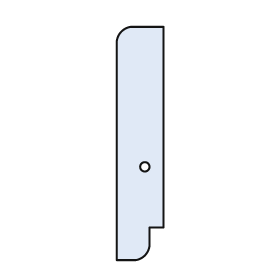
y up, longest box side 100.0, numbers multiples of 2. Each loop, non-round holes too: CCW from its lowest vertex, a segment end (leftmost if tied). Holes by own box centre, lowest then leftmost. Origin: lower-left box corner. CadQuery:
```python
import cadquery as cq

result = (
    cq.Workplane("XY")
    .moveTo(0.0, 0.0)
    .lineTo(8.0, 0.0)
    .threePointArc((12.0, 2.0), (14.0, 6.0))
    .lineTo(14.0, 14.0)
    .lineTo(20.0, 14.0)
    .lineTo(20.0, 100.0)
    .lineTo(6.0, 100.0)
    .threePointArc((2.0, 98.0), (0.0, 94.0))
    .close()
    .moveTo(12.0, 40.0)
    .circle(2.0)
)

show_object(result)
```